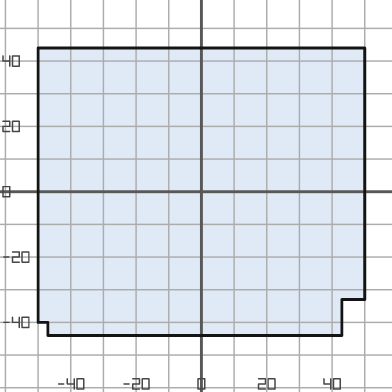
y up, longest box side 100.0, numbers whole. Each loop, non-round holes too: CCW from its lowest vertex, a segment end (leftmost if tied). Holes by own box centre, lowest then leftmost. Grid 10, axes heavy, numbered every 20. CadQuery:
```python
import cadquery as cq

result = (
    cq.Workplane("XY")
    .moveTo(-47.0, -44.0)
    .lineTo(43.0, -44.0)
    .lineTo(43.0, -33.0)
    .lineTo(50.0, -33.0)
    .lineTo(50.0, 44.0)
    .lineTo(-50.0, 44.0)
    .lineTo(-50.0, -40.0)
    .lineTo(-47.0, -40.0)
    .close()
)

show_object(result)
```